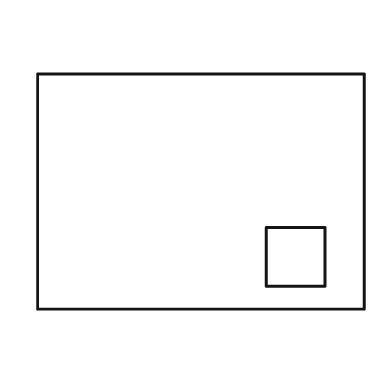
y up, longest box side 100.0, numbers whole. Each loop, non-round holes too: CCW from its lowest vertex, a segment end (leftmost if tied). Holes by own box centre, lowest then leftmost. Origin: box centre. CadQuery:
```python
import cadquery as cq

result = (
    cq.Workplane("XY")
    .moveTo(-50.0, -36.0)
    .lineTo(50.0, -36.0)
    .lineTo(50.0, 36.0)
    .lineTo(-50.0, 36.0)
    .close()
    .moveTo(20.0, -29.0)
    .lineTo(38.0, -29.0)
    .lineTo(38.0, -11.0)
    .lineTo(20.0, -11.0)
    .close()
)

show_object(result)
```